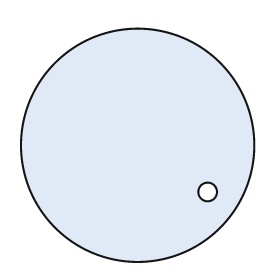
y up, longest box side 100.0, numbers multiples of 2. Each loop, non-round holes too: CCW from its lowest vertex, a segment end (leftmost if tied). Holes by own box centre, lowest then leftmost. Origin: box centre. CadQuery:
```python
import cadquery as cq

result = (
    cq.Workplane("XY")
    .moveTo(0.0, 0.0)
    .circle(50.0)
    .moveTo(30.0, -20.0)
    .circle(4.0)
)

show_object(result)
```